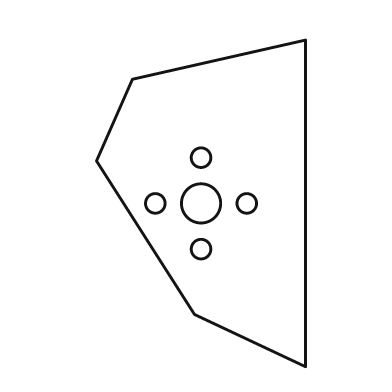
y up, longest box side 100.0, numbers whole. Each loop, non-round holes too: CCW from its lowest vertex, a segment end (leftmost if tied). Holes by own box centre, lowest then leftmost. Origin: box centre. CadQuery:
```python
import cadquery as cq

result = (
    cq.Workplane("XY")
    .moveTo(32.0, -50.0)
    .lineTo(32.0, 50.0)
    .lineTo(-21.0, 38.0)
    .lineTo(-32.0, 13.0)
    .lineTo(-2.0, -34.0)
    .close()
    .moveTo(0.0, -14.0)
    .circle(3.0)
    .moveTo(-14.0, 0.0)
    .circle(3.0)
    .moveTo(0.0, 0.0)
    .circle(6.0)
    .moveTo(14.0, 0.0)
    .circle(3.0)
    .moveTo(0.0, 14.0)
    .circle(3.0)
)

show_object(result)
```